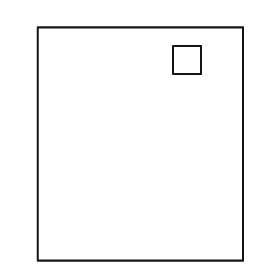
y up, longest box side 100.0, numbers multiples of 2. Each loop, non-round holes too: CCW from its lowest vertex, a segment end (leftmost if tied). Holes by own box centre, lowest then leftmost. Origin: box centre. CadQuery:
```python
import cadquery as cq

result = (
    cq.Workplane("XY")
    .moveTo(-44.0, -50.0)
    .lineTo(44.0, -50.0)
    .lineTo(44.0, 50.0)
    .lineTo(-44.0, 50.0)
    .close()
    .moveTo(14.0, 30.0)
    .lineTo(26.0, 30.0)
    .lineTo(26.0, 42.0)
    .lineTo(14.0, 42.0)
    .close()
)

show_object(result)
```